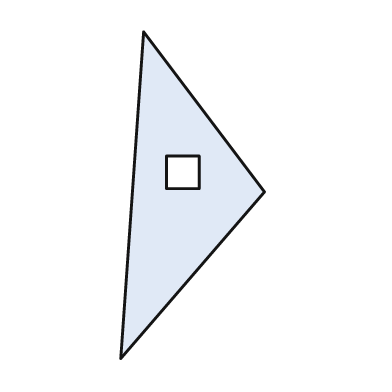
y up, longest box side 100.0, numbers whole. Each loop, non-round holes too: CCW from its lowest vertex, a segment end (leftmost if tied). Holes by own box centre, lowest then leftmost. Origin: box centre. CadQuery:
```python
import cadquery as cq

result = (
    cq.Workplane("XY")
    .moveTo(-22.0, -50.0)
    .lineTo(22.0, 1.0)
    .lineTo(-15.0, 50.0)
    .close()
    .moveTo(-8.0, 2.0)
    .lineTo(2.0, 2.0)
    .lineTo(2.0, 12.0)
    .lineTo(-8.0, 12.0)
    .close()
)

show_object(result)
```